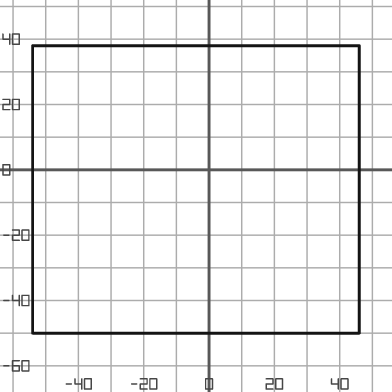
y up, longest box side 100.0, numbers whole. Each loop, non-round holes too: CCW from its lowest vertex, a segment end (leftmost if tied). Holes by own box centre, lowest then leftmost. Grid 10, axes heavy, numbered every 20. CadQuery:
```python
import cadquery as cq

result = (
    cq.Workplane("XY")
    .moveTo(-54.0, -50.0)
    .lineTo(46.0, -50.0)
    .lineTo(46.0, 38.0)
    .lineTo(-54.0, 38.0)
    .close()
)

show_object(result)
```